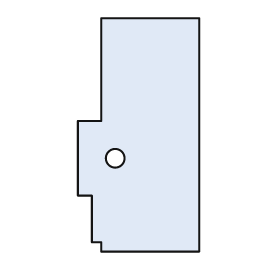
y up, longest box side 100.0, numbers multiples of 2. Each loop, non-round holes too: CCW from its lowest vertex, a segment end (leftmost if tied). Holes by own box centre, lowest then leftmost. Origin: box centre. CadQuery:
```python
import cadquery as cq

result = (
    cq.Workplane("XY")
    .moveTo(-16.0, -50.0)
    .lineTo(26.0, -50.0)
    .lineTo(26.0, 50.0)
    .lineTo(-16.0, 50.0)
    .lineTo(-16.0, 6.0)
    .lineTo(-26.0, 6.0)
    .lineTo(-26.0, -26.0)
    .lineTo(-20.0, -26.0)
    .lineTo(-20.0, -46.0)
    .lineTo(-16.0, -46.0)
    .close()
    .moveTo(-10.0, -10.0)
    .circle(4.0)
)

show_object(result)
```